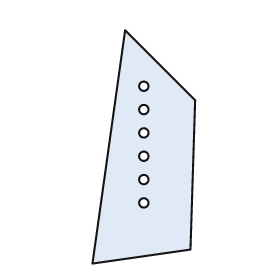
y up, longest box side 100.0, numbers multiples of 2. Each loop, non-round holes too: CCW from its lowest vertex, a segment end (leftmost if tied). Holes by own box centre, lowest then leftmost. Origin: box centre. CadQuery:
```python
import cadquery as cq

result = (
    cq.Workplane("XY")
    .moveTo(-22.0, -50.0)
    .lineTo(20.0, -44.0)
    .lineTo(22.0, 20.0)
    .lineTo(-8.0, 50.0)
    .close()
    .moveTo(0.0, -24.0)
    .circle(2.0)
    .moveTo(0.0, -14.0)
    .circle(2.0)
    .moveTo(0.0, -4.0)
    .circle(2.0)
    .moveTo(0.0, 6.0)
    .circle(2.0)
    .moveTo(0.0, 16.0)
    .circle(2.0)
    .moveTo(0.0, 26.0)
    .circle(2.0)
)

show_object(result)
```